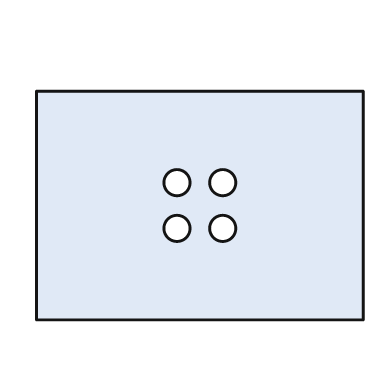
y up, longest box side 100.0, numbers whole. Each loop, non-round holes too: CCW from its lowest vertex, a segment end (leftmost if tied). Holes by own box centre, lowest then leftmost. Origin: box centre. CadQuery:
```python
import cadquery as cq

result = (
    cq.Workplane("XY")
    .moveTo(-50.0, -35.0)
    .lineTo(50.0, -35.0)
    .lineTo(50.0, 35.0)
    .lineTo(-50.0, 35.0)
    .close()
    .moveTo(-7.0, -7.0)
    .circle(4.0)
    .moveTo(7.0, -7.0)
    .circle(4.0)
    .moveTo(-7.0, 7.0)
    .circle(4.0)
    .moveTo(7.0, 7.0)
    .circle(4.0)
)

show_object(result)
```